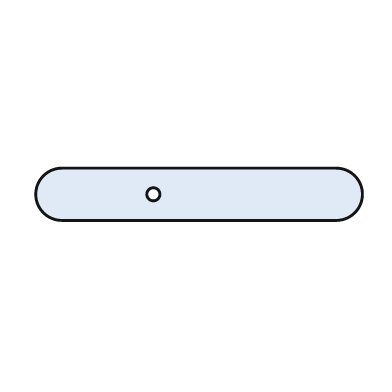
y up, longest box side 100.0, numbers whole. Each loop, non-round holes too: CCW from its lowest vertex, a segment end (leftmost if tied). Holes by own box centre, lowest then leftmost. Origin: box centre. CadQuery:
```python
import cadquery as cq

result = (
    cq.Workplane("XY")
    .moveTo(-42.0, -8.0)
    .lineTo(42.0, -8.0)
    .threePointArc((50.0, 0.0), (42.0, 8.0))
    .lineTo(-42.0, 8.0)
    .threePointArc((-50.0, 0.0), (-42.0, -8.0))
    .close()
    .moveTo(-14.0, 0.0)
    .circle(2.0)
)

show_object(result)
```